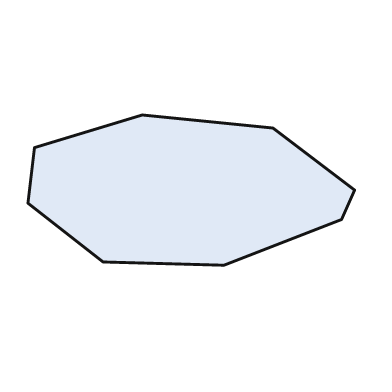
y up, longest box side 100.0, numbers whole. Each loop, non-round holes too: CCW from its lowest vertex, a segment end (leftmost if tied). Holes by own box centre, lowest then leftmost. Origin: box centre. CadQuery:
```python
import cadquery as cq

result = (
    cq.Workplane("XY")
    .moveTo(10.0, -23.0)
    .lineTo(46.0, -9.0)
    .lineTo(50.0, 0.0)
    .lineTo(25.0, 19.0)
    .lineTo(-15.0, 23.0)
    .lineTo(-48.0, 13.0)
    .lineTo(-50.0, -4.0)
    .lineTo(-27.0, -22.0)
    .close()
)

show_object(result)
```